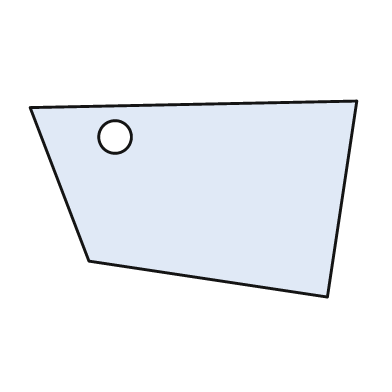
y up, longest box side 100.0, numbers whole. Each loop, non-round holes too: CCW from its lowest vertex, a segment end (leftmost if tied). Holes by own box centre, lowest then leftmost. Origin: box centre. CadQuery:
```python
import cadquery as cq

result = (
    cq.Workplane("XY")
    .moveTo(41.0, -30.0)
    .lineTo(50.0, 30.0)
    .lineTo(-50.0, 28.0)
    .lineTo(-32.0, -19.0)
    .close()
    .moveTo(-24.0, 19.0)
    .circle(5.0)
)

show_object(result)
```